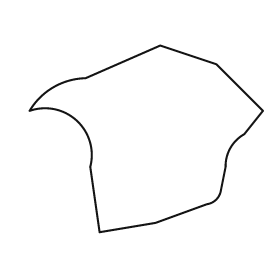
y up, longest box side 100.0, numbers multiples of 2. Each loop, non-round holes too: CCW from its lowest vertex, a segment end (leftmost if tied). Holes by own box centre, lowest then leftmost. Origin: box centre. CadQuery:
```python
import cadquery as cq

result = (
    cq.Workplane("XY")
    .moveTo(-20.0, -40.0)
    .lineTo(4.0, -36.0)
    .lineTo(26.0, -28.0)
    .threePointArc((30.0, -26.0), (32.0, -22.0))
    .lineTo(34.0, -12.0)
    .threePointArc((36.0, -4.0), (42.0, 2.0))
    .lineTo(50.0, 12.0)
    .lineTo(30.0, 32.0)
    .lineTo(6.0, 40.0)
    .lineTo(-26.0, 26.0)
    .threePointArc((-40.0, 22.0), (-50.0, 12.0))
    .threePointArc((-30.0, 8.0), (-24.0, -12.0))
    .close()
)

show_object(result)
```